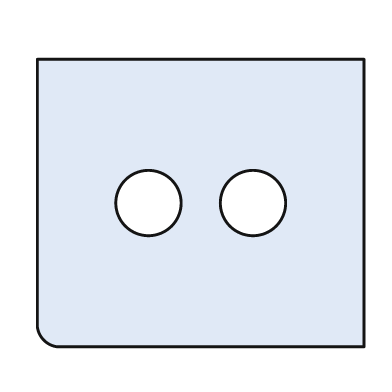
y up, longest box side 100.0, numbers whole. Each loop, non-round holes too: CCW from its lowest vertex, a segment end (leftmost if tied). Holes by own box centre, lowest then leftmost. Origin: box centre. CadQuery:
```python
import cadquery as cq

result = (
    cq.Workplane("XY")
    .moveTo(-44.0, -44.0)
    .lineTo(50.0, -44.0)
    .lineTo(50.0, 44.0)
    .lineTo(-50.0, 44.0)
    .lineTo(-50.0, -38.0)
    .threePointArc((-48.0, -42.0), (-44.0, -44.0))
    .close()
    .moveTo(-16.0, 0.0)
    .circle(10.0)
    .moveTo(16.0, 0.0)
    .circle(10.0)
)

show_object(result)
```